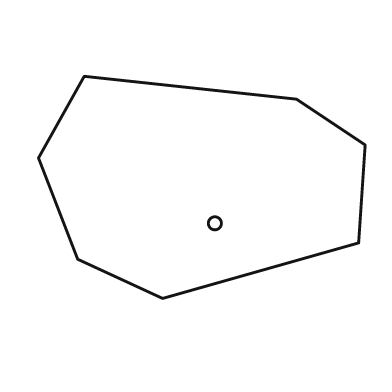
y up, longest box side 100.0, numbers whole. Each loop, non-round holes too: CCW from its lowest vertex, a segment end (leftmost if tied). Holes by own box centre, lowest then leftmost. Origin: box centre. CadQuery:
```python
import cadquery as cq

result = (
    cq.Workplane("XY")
    .moveTo(-12.0, -34.0)
    .lineTo(48.0, -17.0)
    .lineTo(50.0, 13.0)
    .lineTo(29.0, 27.0)
    .lineTo(-36.0, 34.0)
    .lineTo(-50.0, 9.0)
    .lineTo(-38.0, -22.0)
    .close()
    .moveTo(4.0, -11.0)
    .circle(2.0)
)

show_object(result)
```